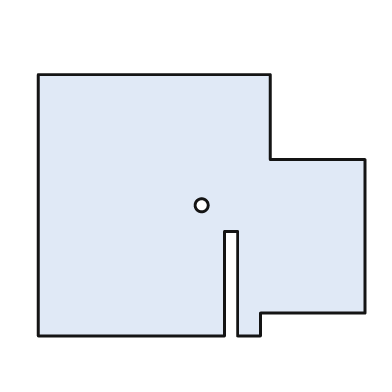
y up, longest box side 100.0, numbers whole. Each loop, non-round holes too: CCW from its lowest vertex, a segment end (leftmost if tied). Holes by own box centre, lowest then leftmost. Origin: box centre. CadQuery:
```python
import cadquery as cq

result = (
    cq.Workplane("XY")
    .moveTo(-50.0, -40.0)
    .lineTo(7.0, -40.0)
    .lineTo(7.0, -8.0)
    .lineTo(11.0, -8.0)
    .lineTo(11.0, -40.0)
    .lineTo(18.0, -40.0)
    .lineTo(18.0, -33.0)
    .lineTo(50.0, -33.0)
    .lineTo(50.0, 14.0)
    .lineTo(21.0, 14.0)
    .lineTo(21.0, 40.0)
    .lineTo(-50.0, 40.0)
    .close()
    .moveTo(0.0, 0.0)
    .circle(2.0)
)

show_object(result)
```